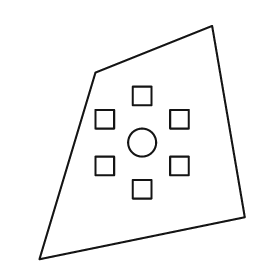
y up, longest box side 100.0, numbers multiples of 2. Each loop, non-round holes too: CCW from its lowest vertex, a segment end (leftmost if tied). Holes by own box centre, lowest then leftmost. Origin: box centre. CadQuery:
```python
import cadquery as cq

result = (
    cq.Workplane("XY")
    .moveTo(-44.0, -50.0)
    .lineTo(44.0, -32.0)
    .lineTo(30.0, 50.0)
    .lineTo(-20.0, 30.0)
    .close()
    .moveTo(-4.0, -24.0)
    .lineTo(4.0, -24.0)
    .lineTo(4.0, -16.0)
    .lineTo(-4.0, -16.0)
    .close()
    .moveTo(-20.0, -14.0)
    .lineTo(-12.0, -14.0)
    .lineTo(-12.0, -6.0)
    .lineTo(-20.0, -6.0)
    .close()
    .moveTo(12.0, -14.0)
    .lineTo(20.0, -14.0)
    .lineTo(20.0, -6.0)
    .lineTo(12.0, -6.0)
    .close()
    .moveTo(0.0, 0.0)
    .circle(6.0)
    .moveTo(-20.0, 6.0)
    .lineTo(-12.0, 6.0)
    .lineTo(-12.0, 14.0)
    .lineTo(-20.0, 14.0)
    .close()
    .moveTo(12.0, 6.0)
    .lineTo(20.0, 6.0)
    .lineTo(20.0, 14.0)
    .lineTo(12.0, 14.0)
    .close()
    .moveTo(-4.0, 16.0)
    .lineTo(4.0, 16.0)
    .lineTo(4.0, 24.0)
    .lineTo(-4.0, 24.0)
    .close()
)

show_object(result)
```